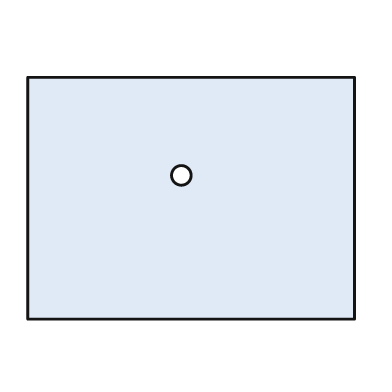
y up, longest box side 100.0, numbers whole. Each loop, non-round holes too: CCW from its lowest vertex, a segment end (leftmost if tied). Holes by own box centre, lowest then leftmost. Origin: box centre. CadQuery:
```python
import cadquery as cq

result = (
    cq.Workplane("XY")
    .moveTo(-50.0, -37.0)
    .lineTo(50.0, -37.0)
    .lineTo(50.0, 37.0)
    .lineTo(-50.0, 37.0)
    .close()
    .moveTo(-3.0, 7.0)
    .circle(3.0)
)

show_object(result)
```